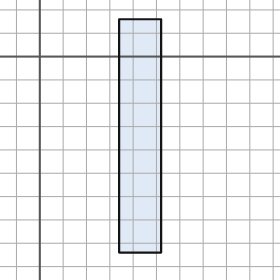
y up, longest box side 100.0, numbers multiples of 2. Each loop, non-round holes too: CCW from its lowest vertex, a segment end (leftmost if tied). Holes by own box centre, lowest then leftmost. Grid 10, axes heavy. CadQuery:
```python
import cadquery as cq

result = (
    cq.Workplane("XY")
    .moveTo(34.0, -84.0)
    .lineTo(52.0, -84.0)
    .lineTo(52.0, 16.0)
    .lineTo(34.0, 16.0)
    .close()
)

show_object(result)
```